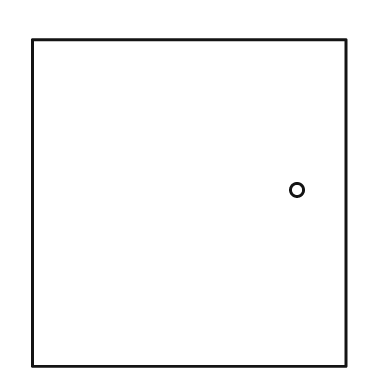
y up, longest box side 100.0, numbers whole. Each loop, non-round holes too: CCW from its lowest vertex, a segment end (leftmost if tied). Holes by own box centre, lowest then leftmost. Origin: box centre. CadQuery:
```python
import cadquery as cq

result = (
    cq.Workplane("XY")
    .moveTo(-48.0, -50.0)
    .lineTo(48.0, -50.0)
    .lineTo(48.0, 50.0)
    .lineTo(-48.0, 50.0)
    .close()
    .moveTo(33.0, 4.0)
    .circle(2.0)
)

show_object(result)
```